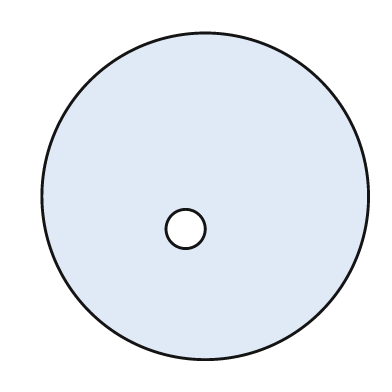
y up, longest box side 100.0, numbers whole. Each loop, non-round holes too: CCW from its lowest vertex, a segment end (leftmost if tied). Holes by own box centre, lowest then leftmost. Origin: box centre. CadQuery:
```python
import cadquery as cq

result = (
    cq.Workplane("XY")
    .moveTo(0.0, 0.0)
    .circle(50.0)
    .moveTo(-6.0, -10.0)
    .circle(6.0)
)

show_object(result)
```